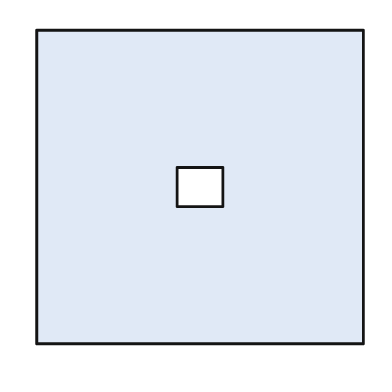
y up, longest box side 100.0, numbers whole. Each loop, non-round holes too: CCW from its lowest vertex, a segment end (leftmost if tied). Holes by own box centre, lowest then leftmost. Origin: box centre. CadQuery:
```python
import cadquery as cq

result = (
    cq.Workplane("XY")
    .moveTo(-50.0, -48.0)
    .lineTo(50.0, -48.0)
    .lineTo(50.0, 48.0)
    .lineTo(-50.0, 48.0)
    .close()
    .moveTo(-7.0, -6.0)
    .lineTo(7.0, -6.0)
    .lineTo(7.0, 6.0)
    .lineTo(-7.0, 6.0)
    .close()
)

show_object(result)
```